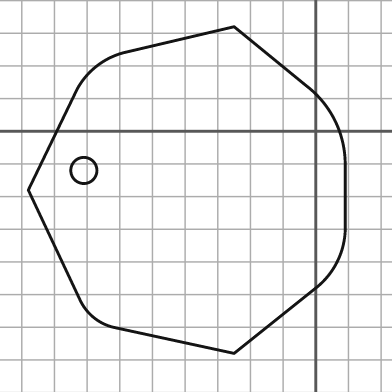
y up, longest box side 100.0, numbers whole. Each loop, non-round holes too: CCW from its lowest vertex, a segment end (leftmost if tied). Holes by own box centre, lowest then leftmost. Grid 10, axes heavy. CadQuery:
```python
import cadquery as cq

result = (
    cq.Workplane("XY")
    .moveTo(-25.0, -68.0)
    .lineTo(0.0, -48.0)
    .threePointArc((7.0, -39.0), (9.0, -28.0))
    .lineTo(9.0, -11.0)
    .threePointArc((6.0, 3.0), (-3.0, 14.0))
    .lineTo(-25.0, 32.0)
    .lineTo(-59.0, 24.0)
    .threePointArc((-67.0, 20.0), (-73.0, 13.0))
    .lineTo(-88.0, -18.0)
    .lineTo(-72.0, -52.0)
    .threePointArc((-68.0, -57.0), (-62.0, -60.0))
    .close()
    .moveTo(-71.0, -12.0)
    .circle(4.0)
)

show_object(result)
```